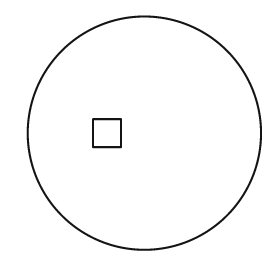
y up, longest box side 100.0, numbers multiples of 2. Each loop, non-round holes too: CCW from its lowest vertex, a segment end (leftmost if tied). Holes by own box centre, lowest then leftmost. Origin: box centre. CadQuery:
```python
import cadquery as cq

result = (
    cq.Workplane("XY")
    .moveTo(0.0, 0.0)
    .circle(50.0)
    .moveTo(-22.0, -6.0)
    .lineTo(-10.0, -6.0)
    .lineTo(-10.0, 6.0)
    .lineTo(-22.0, 6.0)
    .close()
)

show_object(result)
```